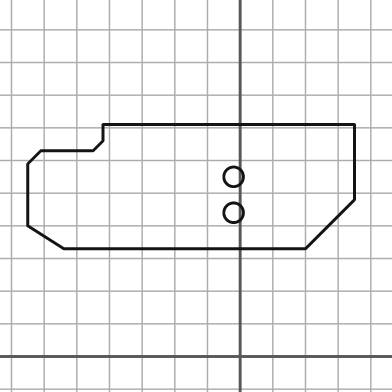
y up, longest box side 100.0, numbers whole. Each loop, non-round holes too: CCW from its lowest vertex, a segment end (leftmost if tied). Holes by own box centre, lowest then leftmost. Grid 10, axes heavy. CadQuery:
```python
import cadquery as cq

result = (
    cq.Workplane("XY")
    .moveTo(-54.0, 33.0)
    .lineTo(20.0, 33.0)
    .lineTo(35.0, 48.0)
    .lineTo(35.0, 71.0)
    .lineTo(-42.0, 71.0)
    .lineTo(-42.0, 66.0)
    .lineTo(-45.0, 63.0)
    .lineTo(-61.0, 63.0)
    .lineTo(-65.0, 59.0)
    .lineTo(-65.0, 40.0)
    .close()
    .moveTo(-2.0, 44.0)
    .circle(3.0)
    .moveTo(-2.0, 55.0)
    .circle(3.0)
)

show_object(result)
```